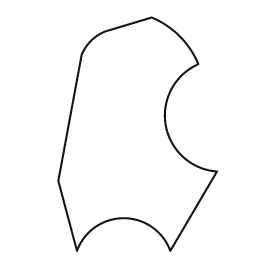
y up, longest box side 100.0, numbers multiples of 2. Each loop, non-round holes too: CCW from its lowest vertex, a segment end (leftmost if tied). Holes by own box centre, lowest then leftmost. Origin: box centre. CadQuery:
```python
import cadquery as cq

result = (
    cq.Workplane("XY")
    .moveTo(-26.0, -50.0)
    .threePointArc((-6.0, -36.0), (14.0, -50.0))
    .lineTo(34.0, -16.0)
    .threePointArc((12.0, 4.0), (26.0, 30.0))
    .threePointArc((18.0, 42.0), (6.0, 50.0))
    .lineTo(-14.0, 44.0)
    .threePointArc((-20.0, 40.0), (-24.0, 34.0))
    .lineTo(-34.0, -20.0)
    .close()
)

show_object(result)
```